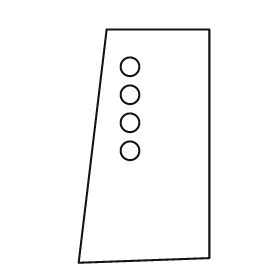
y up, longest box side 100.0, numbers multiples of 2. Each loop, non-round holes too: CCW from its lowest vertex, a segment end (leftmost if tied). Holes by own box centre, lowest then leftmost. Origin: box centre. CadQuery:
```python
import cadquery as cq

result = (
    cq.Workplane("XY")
    .moveTo(-28.0, -50.0)
    .lineTo(28.0, -48.0)
    .lineTo(28.0, 50.0)
    .lineTo(-16.0, 50.0)
    .close()
    .moveTo(-6.0, -2.0)
    .circle(4.0)
    .moveTo(-6.0, 10.0)
    .circle(4.0)
    .moveTo(-6.0, 22.0)
    .circle(4.0)
    .moveTo(-6.0, 34.0)
    .circle(4.0)
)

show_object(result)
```